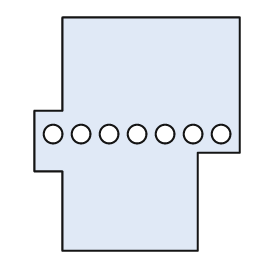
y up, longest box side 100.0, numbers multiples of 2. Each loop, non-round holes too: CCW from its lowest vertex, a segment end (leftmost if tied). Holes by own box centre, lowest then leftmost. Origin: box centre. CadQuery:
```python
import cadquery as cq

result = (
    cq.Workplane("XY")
    .moveTo(-32.0, -50.0)
    .lineTo(26.0, -50.0)
    .lineTo(26.0, -8.0)
    .lineTo(44.0, -8.0)
    .lineTo(44.0, 50.0)
    .lineTo(-32.0, 50.0)
    .lineTo(-32.0, 10.0)
    .lineTo(-44.0, 10.0)
    .lineTo(-44.0, -16.0)
    .lineTo(-32.0, -16.0)
    .close()
    .moveTo(-36.0, 0.0)
    .circle(4.0)
    .moveTo(-24.0, 0.0)
    .circle(4.0)
    .moveTo(-12.0, 0.0)
    .circle(4.0)
    .moveTo(0.0, 0.0)
    .circle(4.0)
    .moveTo(12.0, 0.0)
    .circle(4.0)
    .moveTo(24.0, 0.0)
    .circle(4.0)
    .moveTo(36.0, 0.0)
    .circle(4.0)
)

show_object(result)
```